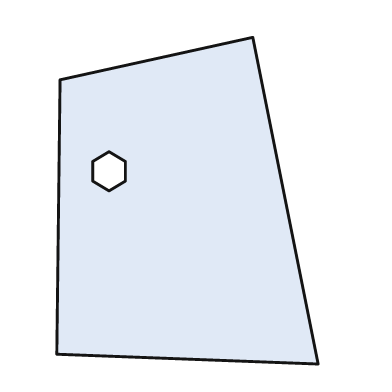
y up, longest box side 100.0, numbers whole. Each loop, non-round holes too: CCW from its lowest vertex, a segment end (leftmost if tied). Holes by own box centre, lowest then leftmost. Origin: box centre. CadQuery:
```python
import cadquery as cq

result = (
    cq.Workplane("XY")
    .moveTo(40.0, -50.0)
    .lineTo(20.0, 50.0)
    .lineTo(-39.0, 37.0)
    .lineTo(-40.0, -47.0)
    .close()
    .moveTo(-24.0, 3.0)
    .lineTo(-19.0, 6.0)
    .lineTo(-19.0, 12.0)
    .lineTo(-24.0, 15.0)
    .lineTo(-29.0, 12.0)
    .lineTo(-29.0, 6.0)
    .close()
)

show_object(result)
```